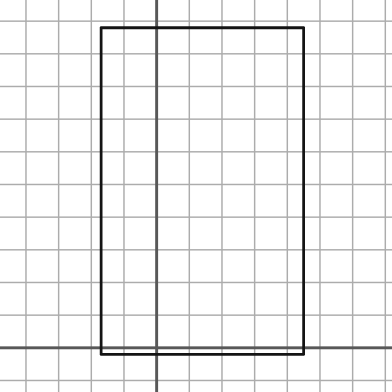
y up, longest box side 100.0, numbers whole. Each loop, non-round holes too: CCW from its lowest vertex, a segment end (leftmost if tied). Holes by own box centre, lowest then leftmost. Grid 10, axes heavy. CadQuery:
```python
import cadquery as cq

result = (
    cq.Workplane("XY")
    .moveTo(-17.0, -2.0)
    .lineTo(45.0, -2.0)
    .lineTo(45.0, 98.0)
    .lineTo(-17.0, 98.0)
    .close()
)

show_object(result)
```